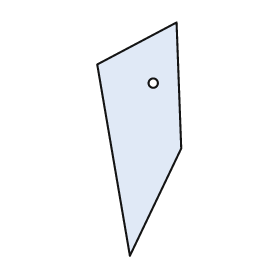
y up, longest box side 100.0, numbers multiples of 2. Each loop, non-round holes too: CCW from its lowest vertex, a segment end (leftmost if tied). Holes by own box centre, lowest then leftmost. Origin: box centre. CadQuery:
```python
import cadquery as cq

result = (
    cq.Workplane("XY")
    .moveTo(-4.0, -50.0)
    .lineTo(18.0, -4.0)
    .lineTo(16.0, 50.0)
    .lineTo(-18.0, 32.0)
    .close()
    .moveTo(6.0, 24.0)
    .circle(2.0)
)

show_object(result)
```